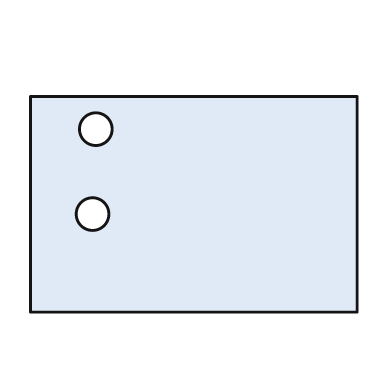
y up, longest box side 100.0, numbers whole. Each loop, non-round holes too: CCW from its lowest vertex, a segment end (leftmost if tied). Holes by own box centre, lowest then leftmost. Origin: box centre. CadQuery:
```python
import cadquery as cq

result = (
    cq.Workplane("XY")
    .moveTo(-50.0, -33.0)
    .lineTo(50.0, -33.0)
    .lineTo(50.0, 33.0)
    .lineTo(-50.0, 33.0)
    .close()
    .moveTo(-31.0, -3.0)
    .circle(5.0)
    .moveTo(-30.0, 23.0)
    .circle(5.0)
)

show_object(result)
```